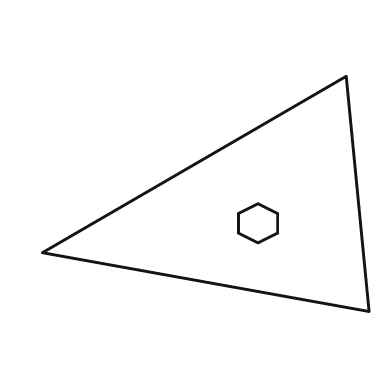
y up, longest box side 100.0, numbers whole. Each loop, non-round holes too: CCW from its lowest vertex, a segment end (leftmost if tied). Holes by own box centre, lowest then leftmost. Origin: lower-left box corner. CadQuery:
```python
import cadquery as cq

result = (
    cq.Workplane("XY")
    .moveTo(100.0, 0.0)
    .lineTo(93.0, 72.0)
    .lineTo(0.0, 18.0)
    .close()
    .moveTo(66.0, 21.0)
    .lineTo(72.0, 24.0)
    .lineTo(72.0, 30.0)
    .lineTo(66.0, 33.0)
    .lineTo(60.0, 30.0)
    .lineTo(60.0, 24.0)
    .close()
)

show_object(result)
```